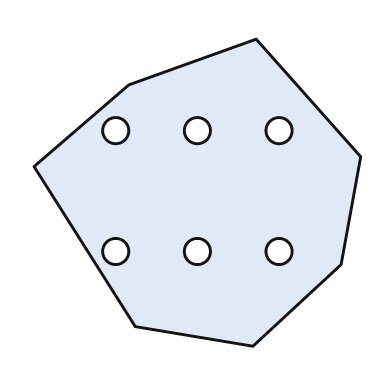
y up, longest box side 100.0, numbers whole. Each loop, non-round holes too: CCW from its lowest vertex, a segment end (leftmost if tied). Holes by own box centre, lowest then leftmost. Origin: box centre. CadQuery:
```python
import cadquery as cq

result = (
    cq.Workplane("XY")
    .moveTo(17.0, -47.0)
    .lineTo(44.0, -22.0)
    .lineTo(50.0, 11.0)
    .lineTo(18.0, 47.0)
    .lineTo(-21.0, 33.0)
    .lineTo(-50.0, 8.0)
    .lineTo(-19.0, -41.0)
    .close()
    .moveTo(-25.0, -18.0)
    .circle(4.0)
    .moveTo(0.0, -18.0)
    .circle(4.0)
    .moveTo(25.0, -18.0)
    .circle(4.0)
    .moveTo(-25.0, 19.0)
    .circle(4.0)
    .moveTo(0.0, 19.0)
    .circle(4.0)
    .moveTo(25.0, 19.0)
    .circle(4.0)
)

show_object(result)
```